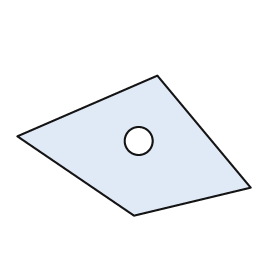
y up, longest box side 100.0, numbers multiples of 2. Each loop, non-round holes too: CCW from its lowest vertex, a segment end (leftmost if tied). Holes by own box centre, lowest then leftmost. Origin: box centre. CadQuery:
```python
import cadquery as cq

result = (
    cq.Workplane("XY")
    .moveTo(0.0, -30.0)
    .lineTo(50.0, -18.0)
    .lineTo(10.0, 30.0)
    .lineTo(-50.0, 4.0)
    .close()
    .moveTo(2.0, 2.0)
    .circle(6.0)
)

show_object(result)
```